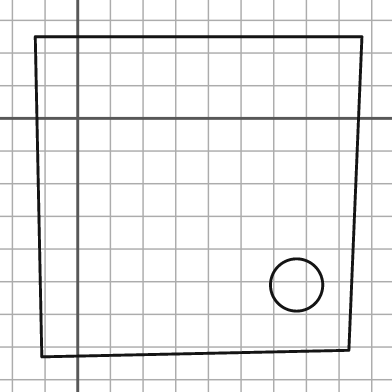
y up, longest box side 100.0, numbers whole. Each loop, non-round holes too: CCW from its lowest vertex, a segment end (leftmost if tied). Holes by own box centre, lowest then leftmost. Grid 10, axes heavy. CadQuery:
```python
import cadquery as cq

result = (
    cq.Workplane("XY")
    .moveTo(-11.0, -73.0)
    .lineTo(83.0, -71.0)
    .lineTo(87.0, 25.0)
    .lineTo(-13.0, 25.0)
    .close()
    .moveTo(67.0, -51.0)
    .circle(8.0)
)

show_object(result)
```